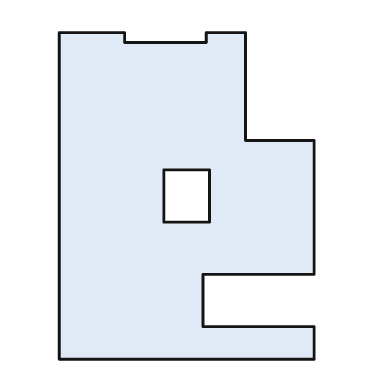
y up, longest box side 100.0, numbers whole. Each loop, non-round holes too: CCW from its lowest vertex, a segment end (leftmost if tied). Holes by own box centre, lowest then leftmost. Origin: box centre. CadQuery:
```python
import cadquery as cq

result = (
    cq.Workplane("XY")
    .moveTo(-39.0, -50.0)
    .lineTo(39.0, -50.0)
    .lineTo(39.0, -40.0)
    .lineTo(5.0, -40.0)
    .lineTo(5.0, -24.0)
    .lineTo(39.0, -24.0)
    .lineTo(39.0, 17.0)
    .lineTo(18.0, 17.0)
    .lineTo(18.0, 50.0)
    .lineTo(6.0, 50.0)
    .lineTo(6.0, 47.0)
    .lineTo(-19.0, 47.0)
    .lineTo(-19.0, 50.0)
    .lineTo(-39.0, 50.0)
    .close()
    .moveTo(-7.0, -8.0)
    .lineTo(7.0, -8.0)
    .lineTo(7.0, 8.0)
    .lineTo(-7.0, 8.0)
    .close()
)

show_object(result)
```